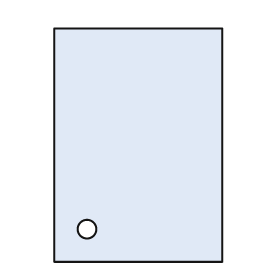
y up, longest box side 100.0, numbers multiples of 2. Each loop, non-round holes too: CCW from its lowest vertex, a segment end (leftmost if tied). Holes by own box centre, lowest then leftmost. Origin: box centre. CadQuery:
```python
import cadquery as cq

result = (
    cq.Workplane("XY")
    .moveTo(-36.0, -50.0)
    .lineTo(36.0, -50.0)
    .lineTo(36.0, 50.0)
    .lineTo(-36.0, 50.0)
    .close()
    .moveTo(-22.0, -36.0)
    .circle(4.0)
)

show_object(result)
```